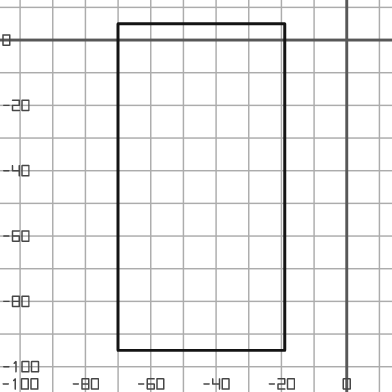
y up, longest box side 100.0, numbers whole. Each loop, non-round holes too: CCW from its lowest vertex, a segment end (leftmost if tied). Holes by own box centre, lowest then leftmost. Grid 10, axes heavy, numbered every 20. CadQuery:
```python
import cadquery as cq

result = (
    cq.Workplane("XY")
    .moveTo(-70.0, -95.0)
    .lineTo(-19.0, -95.0)
    .lineTo(-19.0, 5.0)
    .lineTo(-70.0, 5.0)
    .close()
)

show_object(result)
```